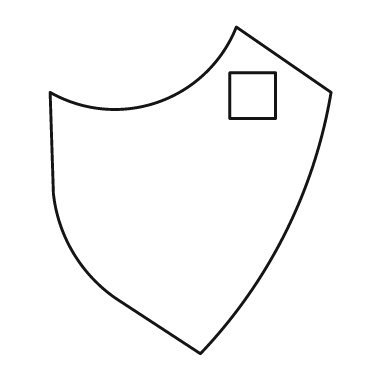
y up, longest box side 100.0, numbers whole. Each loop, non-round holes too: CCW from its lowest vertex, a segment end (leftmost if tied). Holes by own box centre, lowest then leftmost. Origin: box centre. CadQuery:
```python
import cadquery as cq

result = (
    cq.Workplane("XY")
    .moveTo(3.0, -50.0)
    .threePointArc((29.0, -13.0), (43.0, 30.0))
    .lineTo(14.0, 50.0)
    .threePointArc((-10.0, 27.0), (-43.0, 30.0))
    .lineTo(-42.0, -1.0)
    .threePointArc((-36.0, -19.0), (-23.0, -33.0))
    .close()
    .moveTo(12.0, 22.0)
    .lineTo(26.0, 22.0)
    .lineTo(26.0, 36.0)
    .lineTo(12.0, 36.0)
    .close()
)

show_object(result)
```